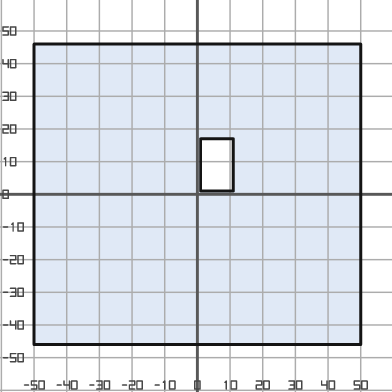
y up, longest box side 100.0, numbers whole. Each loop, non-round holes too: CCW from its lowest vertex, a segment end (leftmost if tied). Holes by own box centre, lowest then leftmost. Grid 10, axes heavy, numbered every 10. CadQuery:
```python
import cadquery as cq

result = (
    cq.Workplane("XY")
    .moveTo(-50.0, -46.0)
    .lineTo(50.0, -46.0)
    .lineTo(50.0, 46.0)
    .lineTo(-50.0, 46.0)
    .close()
    .moveTo(1.0, 1.0)
    .lineTo(11.0, 1.0)
    .lineTo(11.0, 17.0)
    .lineTo(1.0, 17.0)
    .close()
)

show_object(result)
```